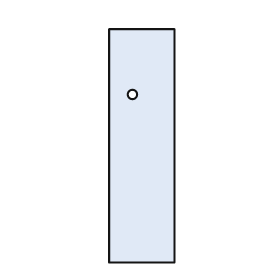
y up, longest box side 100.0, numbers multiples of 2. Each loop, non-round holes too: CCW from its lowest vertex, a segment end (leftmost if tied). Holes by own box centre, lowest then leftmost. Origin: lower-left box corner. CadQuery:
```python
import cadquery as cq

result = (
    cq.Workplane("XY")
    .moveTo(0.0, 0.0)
    .lineTo(28.0, 0.0)
    .lineTo(28.0, 100.0)
    .lineTo(0.0, 100.0)
    .close()
    .moveTo(10.0, 72.0)
    .circle(2.0)
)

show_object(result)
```